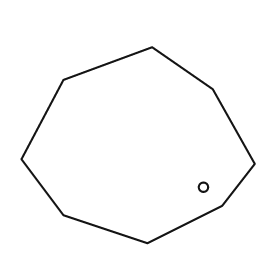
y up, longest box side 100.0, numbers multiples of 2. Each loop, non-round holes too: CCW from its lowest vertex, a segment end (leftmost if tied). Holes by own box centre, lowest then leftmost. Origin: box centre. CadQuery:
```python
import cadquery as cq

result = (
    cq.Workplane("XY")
    .moveTo(4.0, -42.0)
    .lineTo(36.0, -26.0)
    .lineTo(50.0, -8.0)
    .lineTo(32.0, 24.0)
    .lineTo(6.0, 42.0)
    .lineTo(-32.0, 28.0)
    .lineTo(-50.0, -6.0)
    .lineTo(-32.0, -30.0)
    .close()
    .moveTo(28.0, -18.0)
    .circle(2.0)
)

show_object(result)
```